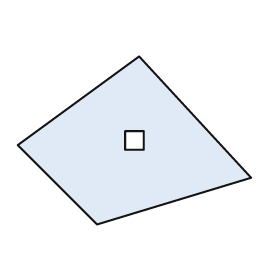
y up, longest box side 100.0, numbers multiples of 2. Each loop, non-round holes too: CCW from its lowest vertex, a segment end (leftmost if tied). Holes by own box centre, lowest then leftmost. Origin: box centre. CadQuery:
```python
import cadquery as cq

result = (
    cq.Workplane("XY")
    .moveTo(-16.0, -36.0)
    .lineTo(50.0, -16.0)
    .lineTo(2.0, 36.0)
    .lineTo(-50.0, -2.0)
    .close()
    .moveTo(-4.0, -4.0)
    .lineTo(4.0, -4.0)
    .lineTo(4.0, 4.0)
    .lineTo(-4.0, 4.0)
    .close()
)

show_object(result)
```